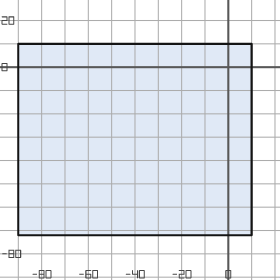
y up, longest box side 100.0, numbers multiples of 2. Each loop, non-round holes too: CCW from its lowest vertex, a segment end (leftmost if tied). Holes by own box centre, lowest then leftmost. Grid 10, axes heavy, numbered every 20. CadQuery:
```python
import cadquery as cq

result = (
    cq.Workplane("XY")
    .moveTo(-90.0, -72.0)
    .lineTo(10.0, -72.0)
    .lineTo(10.0, 10.0)
    .lineTo(-90.0, 10.0)
    .close()
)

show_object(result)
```